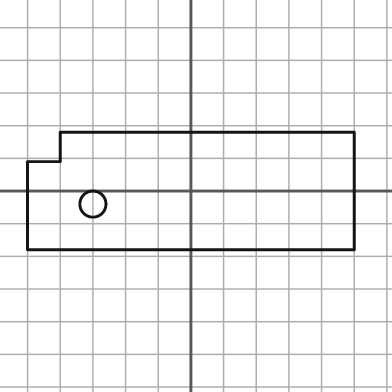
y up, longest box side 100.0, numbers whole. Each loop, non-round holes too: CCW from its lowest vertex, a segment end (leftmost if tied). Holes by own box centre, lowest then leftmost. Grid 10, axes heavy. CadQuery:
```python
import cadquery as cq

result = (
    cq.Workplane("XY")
    .moveTo(-50.0, -18.0)
    .lineTo(50.0, -18.0)
    .lineTo(50.0, 18.0)
    .lineTo(-40.0, 18.0)
    .lineTo(-40.0, 9.0)
    .lineTo(-50.0, 9.0)
    .close()
    .moveTo(-30.0, -4.0)
    .circle(4.0)
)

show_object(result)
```